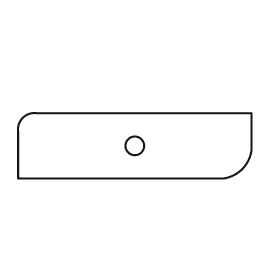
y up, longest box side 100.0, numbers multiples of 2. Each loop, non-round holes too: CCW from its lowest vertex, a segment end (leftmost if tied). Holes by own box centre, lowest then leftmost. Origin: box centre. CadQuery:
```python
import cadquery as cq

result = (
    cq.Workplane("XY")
    .moveTo(-50.0, -14.0)
    .lineTo(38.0, -14.0)
    .threePointArc((46.0, -10.0), (50.0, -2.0))
    .lineTo(50.0, 14.0)
    .lineTo(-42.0, 14.0)
    .threePointArc((-48.0, 12.0), (-50.0, 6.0))
    .close()
    .moveTo(0.0, 0.0)
    .circle(4.0)
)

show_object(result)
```